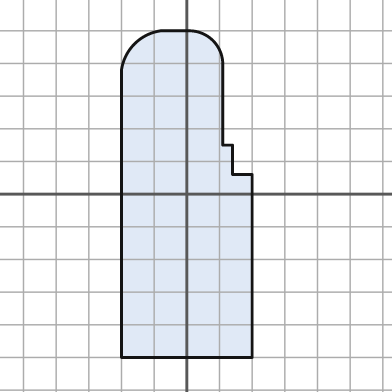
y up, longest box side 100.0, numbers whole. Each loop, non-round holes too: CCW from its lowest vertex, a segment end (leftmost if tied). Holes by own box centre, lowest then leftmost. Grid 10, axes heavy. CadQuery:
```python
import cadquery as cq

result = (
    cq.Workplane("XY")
    .moveTo(-20.0, -50.0)
    .lineTo(20.0, -50.0)
    .lineTo(20.0, 6.0)
    .lineTo(14.0, 6.0)
    .lineTo(14.0, 15.0)
    .lineTo(11.0, 15.0)
    .lineTo(11.0, 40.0)
    .threePointArc((8.0, 47.0), (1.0, 50.0))
    .lineTo(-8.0, 50.0)
    .threePointArc((-16.0, 46.0), (-20.0, 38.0))
    .close()
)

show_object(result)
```